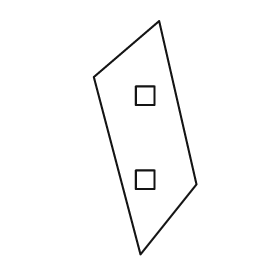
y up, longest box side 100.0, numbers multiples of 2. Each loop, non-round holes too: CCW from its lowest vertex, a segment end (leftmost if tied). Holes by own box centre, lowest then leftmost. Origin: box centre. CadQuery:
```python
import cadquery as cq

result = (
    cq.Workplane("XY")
    .moveTo(-2.0, -50.0)
    .lineTo(22.0, -20.0)
    .lineTo(6.0, 50.0)
    .lineTo(-22.0, 26.0)
    .close()
    .moveTo(-4.0, -22.0)
    .lineTo(4.0, -22.0)
    .lineTo(4.0, -14.0)
    .lineTo(-4.0, -14.0)
    .close()
    .moveTo(-4.0, 14.0)
    .lineTo(4.0, 14.0)
    .lineTo(4.0, 22.0)
    .lineTo(-4.0, 22.0)
    .close()
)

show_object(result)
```